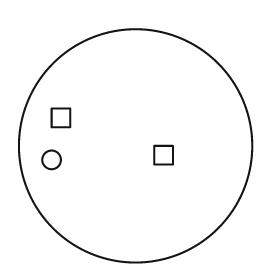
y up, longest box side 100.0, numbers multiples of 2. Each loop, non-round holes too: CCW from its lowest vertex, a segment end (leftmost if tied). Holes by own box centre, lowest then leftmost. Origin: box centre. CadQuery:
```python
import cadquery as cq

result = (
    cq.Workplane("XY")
    .moveTo(0.0, 0.0)
    .circle(50.0)
    .moveTo(-36.0, -6.0)
    .circle(4.0)
    .moveTo(8.0, -8.0)
    .lineTo(16.0, -8.0)
    .lineTo(16.0, 0.0)
    .lineTo(8.0, 0.0)
    .close()
    .moveTo(-36.0, 8.0)
    .lineTo(-28.0, 8.0)
    .lineTo(-28.0, 16.0)
    .lineTo(-36.0, 16.0)
    .close()
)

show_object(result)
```